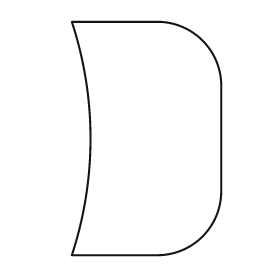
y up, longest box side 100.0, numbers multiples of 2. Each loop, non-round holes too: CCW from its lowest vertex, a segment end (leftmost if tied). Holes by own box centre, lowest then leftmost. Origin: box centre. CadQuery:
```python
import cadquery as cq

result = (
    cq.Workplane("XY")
    .moveTo(-32.0, -50.0)
    .lineTo(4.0, -50.0)
    .threePointArc((24.0, -42.0), (32.0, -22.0))
    .lineTo(32.0, 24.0)
    .threePointArc((24.0, 42.0), (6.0, 50.0))
    .lineTo(-32.0, 50.0)
    .threePointArc((-24.0, 0.0), (-32.0, -50.0))
    .close()
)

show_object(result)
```